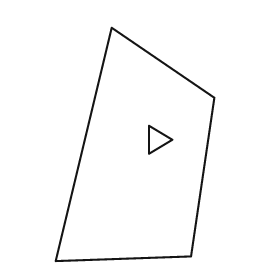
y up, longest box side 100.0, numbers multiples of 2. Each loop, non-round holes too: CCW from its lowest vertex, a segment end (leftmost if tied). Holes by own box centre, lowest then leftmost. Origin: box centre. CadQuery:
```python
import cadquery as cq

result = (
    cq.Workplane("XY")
    .moveTo(-34.0, -50.0)
    .lineTo(24.0, -48.0)
    .lineTo(34.0, 20.0)
    .lineTo(-10.0, 50.0)
    .close()
    .moveTo(6.0, -4.0)
    .lineTo(16.0, 2.0)
    .lineTo(6.0, 8.0)
    .close()
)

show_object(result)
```